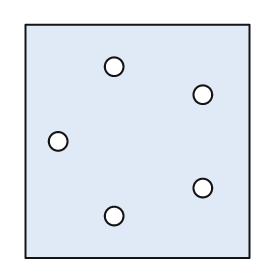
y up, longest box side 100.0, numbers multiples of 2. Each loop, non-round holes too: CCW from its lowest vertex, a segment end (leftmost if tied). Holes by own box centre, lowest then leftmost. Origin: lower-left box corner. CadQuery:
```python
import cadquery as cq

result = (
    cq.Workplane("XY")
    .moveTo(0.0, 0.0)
    .lineTo(96.0, 0.0)
    .lineTo(96.0, 100.0)
    .lineTo(0.0, 100.0)
    .close()
    .moveTo(38.0, 18.0)
    .circle(4.0)
    .moveTo(76.0, 30.0)
    .circle(4.0)
    .moveTo(14.0, 50.0)
    .circle(4.0)
    .moveTo(76.0, 70.0)
    .circle(4.0)
    .moveTo(38.0, 82.0)
    .circle(4.0)
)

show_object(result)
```